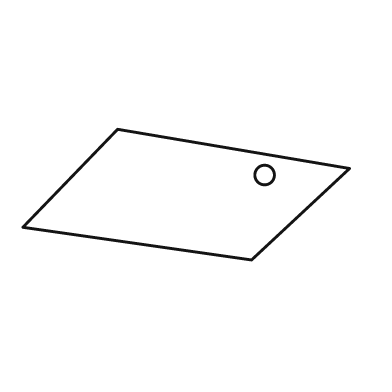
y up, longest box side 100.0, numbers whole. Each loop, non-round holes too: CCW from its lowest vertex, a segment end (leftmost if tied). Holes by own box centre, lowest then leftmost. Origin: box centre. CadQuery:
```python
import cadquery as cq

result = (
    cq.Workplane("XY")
    .moveTo(20.0, -20.0)
    .lineTo(50.0, 8.0)
    .lineTo(-21.0, 20.0)
    .lineTo(-50.0, -10.0)
    .close()
    .moveTo(24.0, 6.0)
    .circle(3.0)
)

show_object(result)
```